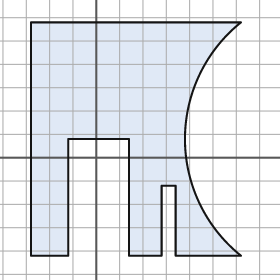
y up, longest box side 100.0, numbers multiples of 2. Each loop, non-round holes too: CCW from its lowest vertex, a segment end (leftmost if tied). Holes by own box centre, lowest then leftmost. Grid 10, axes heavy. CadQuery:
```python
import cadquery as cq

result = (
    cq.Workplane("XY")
    .moveTo(-28.0, -42.0)
    .lineTo(-12.0, -42.0)
    .lineTo(-12.0, 8.0)
    .lineTo(14.0, 8.0)
    .lineTo(14.0, -42.0)
    .lineTo(28.0, -42.0)
    .lineTo(28.0, -12.0)
    .lineTo(34.0, -12.0)
    .lineTo(34.0, -42.0)
    .lineTo(62.0, -42.0)
    .threePointArc((38.0, 8.0), (62.0, 58.0))
    .lineTo(-28.0, 58.0)
    .close()
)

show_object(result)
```